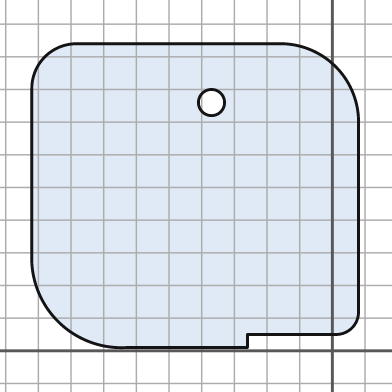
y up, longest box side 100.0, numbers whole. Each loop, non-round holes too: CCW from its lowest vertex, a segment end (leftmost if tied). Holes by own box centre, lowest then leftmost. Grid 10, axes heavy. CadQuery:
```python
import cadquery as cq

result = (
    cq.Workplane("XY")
    .moveTo(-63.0, 1.0)
    .lineTo(-26.0, 1.0)
    .lineTo(-26.0, 5.0)
    .lineTo(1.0, 5.0)
    .threePointArc((6.0, 7.0), (8.0, 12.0))
    .lineTo(8.0, 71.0)
    .threePointArc((1.0, 87.0), (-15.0, 94.0))
    .lineTo(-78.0, 94.0)
    .threePointArc((-88.0, 90.0), (-92.0, 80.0))
    .lineTo(-92.0, 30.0)
    .threePointArc((-84.0, 9.0), (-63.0, 1.0))
    .close()
    .moveTo(-37.0, 76.0)
    .circle(4.0)
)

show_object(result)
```